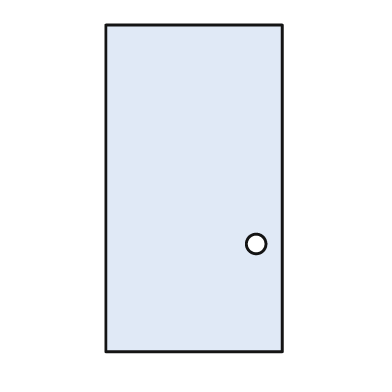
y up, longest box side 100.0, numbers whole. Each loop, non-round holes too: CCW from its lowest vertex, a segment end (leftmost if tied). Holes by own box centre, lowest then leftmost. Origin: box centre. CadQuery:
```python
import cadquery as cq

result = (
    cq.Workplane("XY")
    .moveTo(-27.0, -50.0)
    .lineTo(27.0, -50.0)
    .lineTo(27.0, 50.0)
    .lineTo(-27.0, 50.0)
    .close()
    .moveTo(19.0, -17.0)
    .circle(3.0)
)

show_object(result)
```